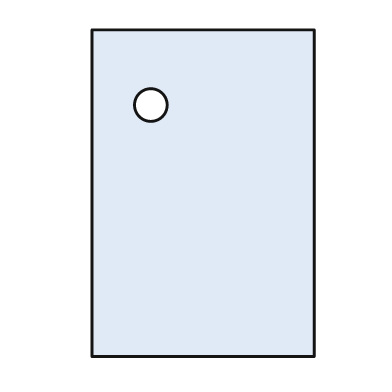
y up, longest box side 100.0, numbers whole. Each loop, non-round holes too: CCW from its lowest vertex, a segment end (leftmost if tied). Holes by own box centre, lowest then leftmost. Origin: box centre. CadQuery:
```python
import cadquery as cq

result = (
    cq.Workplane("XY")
    .moveTo(-34.0, -50.0)
    .lineTo(34.0, -50.0)
    .lineTo(34.0, 50.0)
    .lineTo(-34.0, 50.0)
    .close()
    .moveTo(-16.0, 27.0)
    .circle(5.0)
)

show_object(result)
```